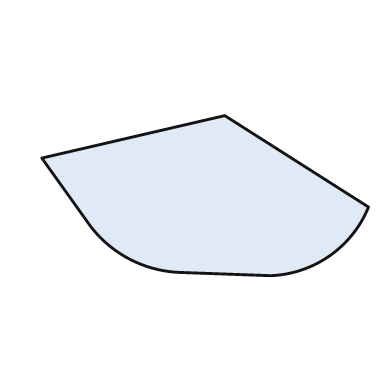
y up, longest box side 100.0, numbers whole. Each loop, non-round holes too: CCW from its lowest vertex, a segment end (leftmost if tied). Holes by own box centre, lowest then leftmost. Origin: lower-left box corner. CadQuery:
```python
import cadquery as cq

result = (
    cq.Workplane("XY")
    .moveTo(70.0, 0.0)
    .threePointArc((88.0, 6.0), (100.0, 21.0))
    .lineTo(56.0, 49.0)
    .lineTo(0.0, 36.0)
    .lineTo(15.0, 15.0)
    .threePointArc((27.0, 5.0), (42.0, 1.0))
    .close()
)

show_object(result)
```